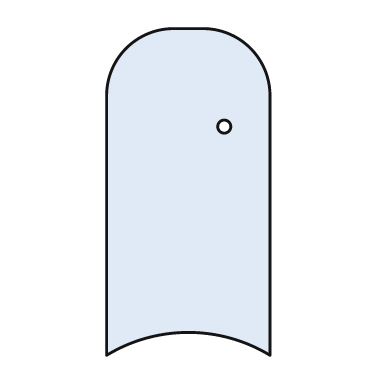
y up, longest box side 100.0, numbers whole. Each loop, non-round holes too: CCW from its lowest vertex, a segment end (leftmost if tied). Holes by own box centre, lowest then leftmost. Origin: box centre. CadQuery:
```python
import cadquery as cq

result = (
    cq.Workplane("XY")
    .moveTo(-25.0, -50.0)
    .threePointArc((0.0, -43.0), (25.0, -50.0))
    .lineTo(25.0, 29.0)
    .threePointArc((19.0, 44.0), (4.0, 50.0))
    .lineTo(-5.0, 50.0)
    .threePointArc((-19.0, 44.0), (-25.0, 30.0))
    .close()
    .moveTo(11.0, 20.0)
    .circle(2.0)
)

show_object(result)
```